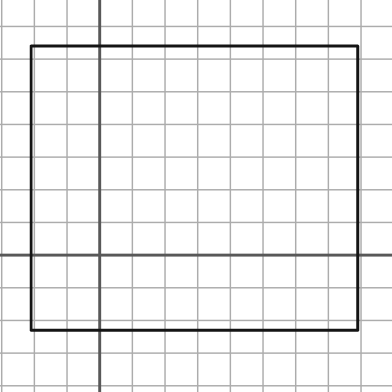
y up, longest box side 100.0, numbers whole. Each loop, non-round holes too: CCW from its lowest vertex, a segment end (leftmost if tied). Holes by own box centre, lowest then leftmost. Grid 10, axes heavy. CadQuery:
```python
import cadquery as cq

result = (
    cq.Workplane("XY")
    .moveTo(-21.0, -23.0)
    .lineTo(79.0, -23.0)
    .lineTo(79.0, 64.0)
    .lineTo(-21.0, 64.0)
    .close()
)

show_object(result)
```